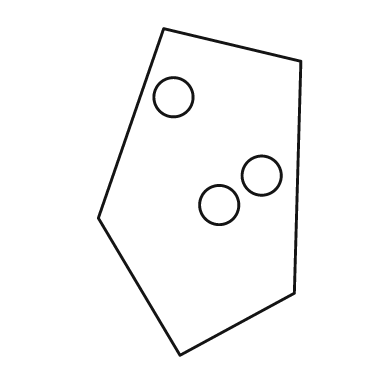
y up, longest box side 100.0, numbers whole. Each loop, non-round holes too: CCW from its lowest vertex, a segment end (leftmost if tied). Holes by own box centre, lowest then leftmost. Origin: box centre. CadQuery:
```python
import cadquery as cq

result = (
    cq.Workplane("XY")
    .moveTo(-6.0, -50.0)
    .lineTo(29.0, -31.0)
    .lineTo(31.0, 40.0)
    .lineTo(-11.0, 50.0)
    .lineTo(-31.0, -8.0)
    .close()
    .moveTo(6.0, -4.0)
    .circle(6.0)
    .moveTo(19.0, 5.0)
    .circle(6.0)
    .moveTo(-8.0, 29.0)
    .circle(6.0)
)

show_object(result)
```